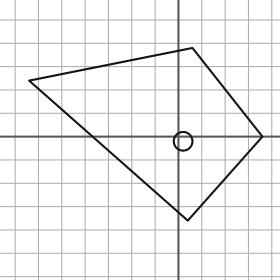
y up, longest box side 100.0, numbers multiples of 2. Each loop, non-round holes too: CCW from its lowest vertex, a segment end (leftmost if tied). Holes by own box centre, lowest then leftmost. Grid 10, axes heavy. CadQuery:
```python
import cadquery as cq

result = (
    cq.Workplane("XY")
    .moveTo(4.0, -36.0)
    .lineTo(36.0, 0.0)
    .lineTo(6.0, 38.0)
    .lineTo(-64.0, 24.0)
    .close()
    .moveTo(2.0, -2.0)
    .circle(4.0)
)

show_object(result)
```